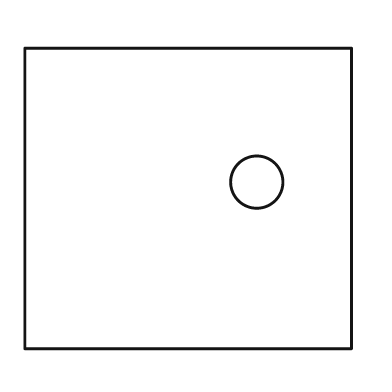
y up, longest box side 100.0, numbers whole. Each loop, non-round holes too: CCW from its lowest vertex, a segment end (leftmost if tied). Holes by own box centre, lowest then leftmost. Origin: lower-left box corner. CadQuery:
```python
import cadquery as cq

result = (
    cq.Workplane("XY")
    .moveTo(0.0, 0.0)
    .lineTo(100.0, 0.0)
    .lineTo(100.0, 92.0)
    .lineTo(0.0, 92.0)
    .close()
    .moveTo(71.0, 51.0)
    .circle(8.0)
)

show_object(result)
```